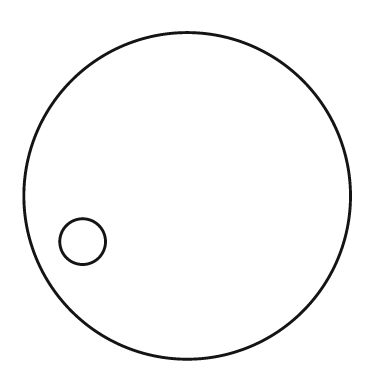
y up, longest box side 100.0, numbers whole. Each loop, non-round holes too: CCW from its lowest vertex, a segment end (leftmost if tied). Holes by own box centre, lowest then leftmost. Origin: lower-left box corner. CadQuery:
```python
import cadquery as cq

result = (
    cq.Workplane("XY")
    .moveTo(50.0, 50.0)
    .circle(50.0)
    .moveTo(18.0, 36.0)
    .circle(7.0)
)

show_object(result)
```